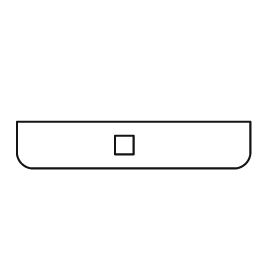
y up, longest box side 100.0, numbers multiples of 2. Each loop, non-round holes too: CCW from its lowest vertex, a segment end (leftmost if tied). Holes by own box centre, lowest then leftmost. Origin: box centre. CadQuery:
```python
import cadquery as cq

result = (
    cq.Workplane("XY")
    .moveTo(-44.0, -10.0)
    .lineTo(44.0, -10.0)
    .threePointArc((48.0, -8.0), (50.0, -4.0))
    .lineTo(50.0, 10.0)
    .lineTo(-50.0, 10.0)
    .lineTo(-50.0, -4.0)
    .threePointArc((-48.0, -8.0), (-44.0, -10.0))
    .close()
    .moveTo(-8.0, -4.0)
    .lineTo(0.0, -4.0)
    .lineTo(0.0, 4.0)
    .lineTo(-8.0, 4.0)
    .close()
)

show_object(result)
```